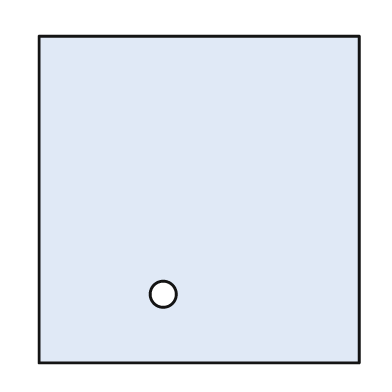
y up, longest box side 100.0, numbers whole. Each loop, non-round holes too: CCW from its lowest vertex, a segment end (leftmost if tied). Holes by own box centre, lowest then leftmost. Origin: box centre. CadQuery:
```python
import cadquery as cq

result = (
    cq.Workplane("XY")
    .moveTo(-49.0, -50.0)
    .lineTo(49.0, -50.0)
    .lineTo(49.0, 50.0)
    .lineTo(-49.0, 50.0)
    .close()
    .moveTo(-11.0, -29.0)
    .circle(4.0)
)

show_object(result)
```